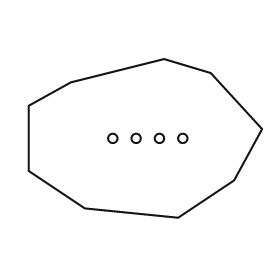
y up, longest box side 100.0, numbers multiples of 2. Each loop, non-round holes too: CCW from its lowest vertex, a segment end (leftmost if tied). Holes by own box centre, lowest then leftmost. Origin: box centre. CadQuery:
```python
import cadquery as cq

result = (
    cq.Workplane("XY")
    .moveTo(14.0, -34.0)
    .lineTo(38.0, -18.0)
    .lineTo(50.0, 4.0)
    .lineTo(28.0, 28.0)
    .lineTo(8.0, 34.0)
    .lineTo(-32.0, 24.0)
    .lineTo(-50.0, 14.0)
    .lineTo(-50.0, -14.0)
    .lineTo(-26.0, -30.0)
    .close()
    .moveTo(-14.0, 0.0)
    .circle(2.0)
    .moveTo(-4.0, 0.0)
    .circle(2.0)
    .moveTo(6.0, 0.0)
    .circle(2.0)
    .moveTo(16.0, 0.0)
    .circle(2.0)
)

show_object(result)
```